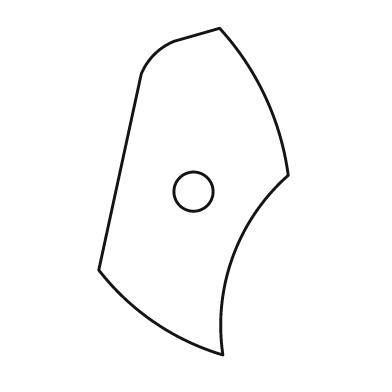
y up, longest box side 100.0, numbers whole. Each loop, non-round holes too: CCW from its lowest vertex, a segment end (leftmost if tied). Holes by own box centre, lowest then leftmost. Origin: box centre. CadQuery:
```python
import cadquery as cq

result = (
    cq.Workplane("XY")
    .moveTo(9.0, -50.0)
    .threePointArc((12.0, -20.0), (29.0, 5.0))
    .threePointArc((22.0, 29.0), (8.0, 50.0))
    .lineTo(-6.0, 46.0)
    .threePointArc((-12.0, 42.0), (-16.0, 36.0))
    .lineTo(-29.0, -24.0)
    .threePointArc((-12.0, -40.0), (9.0, -50.0))
    .close()
    .moveTo(0.0, 0.0)
    .circle(6.0)
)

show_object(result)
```